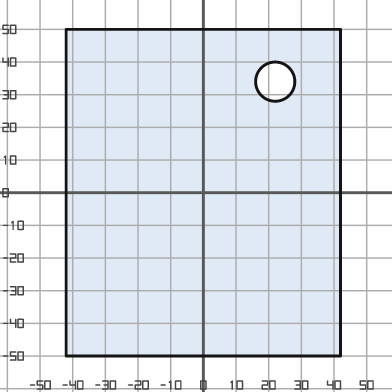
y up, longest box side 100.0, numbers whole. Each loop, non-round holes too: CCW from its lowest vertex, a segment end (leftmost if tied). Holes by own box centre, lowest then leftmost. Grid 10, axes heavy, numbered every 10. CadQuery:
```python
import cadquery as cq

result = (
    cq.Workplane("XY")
    .moveTo(-42.0, -50.0)
    .lineTo(42.0, -50.0)
    .lineTo(42.0, 50.0)
    .lineTo(-42.0, 50.0)
    .close()
    .moveTo(22.0, 34.0)
    .circle(6.0)
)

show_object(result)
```